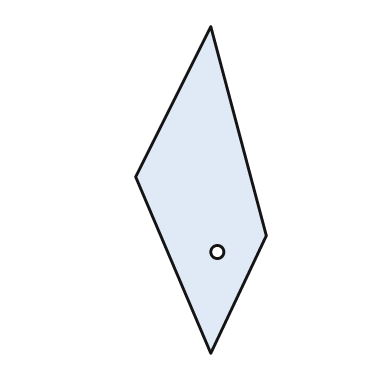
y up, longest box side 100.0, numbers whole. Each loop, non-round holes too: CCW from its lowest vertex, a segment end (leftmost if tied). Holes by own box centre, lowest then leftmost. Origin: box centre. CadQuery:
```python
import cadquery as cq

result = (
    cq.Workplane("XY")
    .moveTo(3.0, -50.0)
    .lineTo(20.0, -14.0)
    .lineTo(3.0, 50.0)
    .lineTo(-20.0, 4.0)
    .close()
    .moveTo(5.0, -19.0)
    .circle(2.0)
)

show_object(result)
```